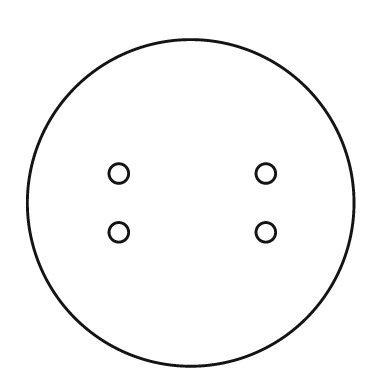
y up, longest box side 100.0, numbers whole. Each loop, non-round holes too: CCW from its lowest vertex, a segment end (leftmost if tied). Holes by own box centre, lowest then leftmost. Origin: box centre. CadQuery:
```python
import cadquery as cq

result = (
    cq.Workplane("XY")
    .moveTo(0.0, 0.0)
    .circle(50.0)
    .moveTo(-22.0, -9.0)
    .circle(3.0)
    .moveTo(23.0, -9.0)
    .circle(3.0)
    .moveTo(-22.0, 9.0)
    .circle(3.0)
    .moveTo(23.0, 9.0)
    .circle(3.0)
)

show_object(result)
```